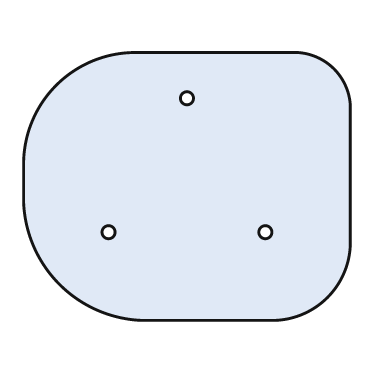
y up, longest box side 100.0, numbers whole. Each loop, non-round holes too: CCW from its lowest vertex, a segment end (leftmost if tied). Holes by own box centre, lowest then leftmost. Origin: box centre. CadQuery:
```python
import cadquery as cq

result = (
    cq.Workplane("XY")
    .moveTo(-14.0, -41.0)
    .lineTo(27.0, -41.0)
    .threePointArc((43.0, -34.0), (50.0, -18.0))
    .lineTo(50.0, 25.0)
    .threePointArc((45.0, 36.0), (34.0, 41.0))
    .lineTo(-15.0, 41.0)
    .threePointArc((-40.0, 31.0), (-50.0, 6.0))
    .lineTo(-50.0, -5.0)
    .threePointArc((-39.0, -30.0), (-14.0, -41.0))
    .close()
    .moveTo(-24.0, -14.0)
    .circle(2.0)
    .moveTo(24.0, -14.0)
    .circle(2.0)
    .moveTo(0.0, 27.0)
    .circle(2.0)
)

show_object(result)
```